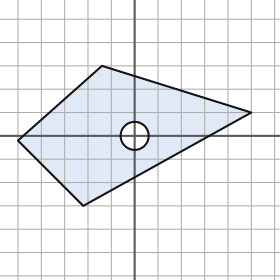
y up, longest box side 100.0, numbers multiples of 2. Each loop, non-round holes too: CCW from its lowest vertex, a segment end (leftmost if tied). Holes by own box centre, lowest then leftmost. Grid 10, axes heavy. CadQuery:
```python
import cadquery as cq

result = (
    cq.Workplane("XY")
    .moveTo(-22.0, -30.0)
    .lineTo(50.0, 10.0)
    .lineTo(-14.0, 30.0)
    .lineTo(-50.0, -2.0)
    .close()
    .moveTo(0.0, 0.0)
    .circle(6.0)
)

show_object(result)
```